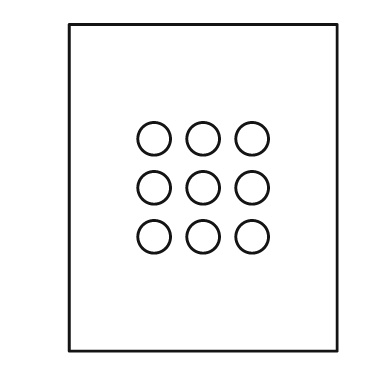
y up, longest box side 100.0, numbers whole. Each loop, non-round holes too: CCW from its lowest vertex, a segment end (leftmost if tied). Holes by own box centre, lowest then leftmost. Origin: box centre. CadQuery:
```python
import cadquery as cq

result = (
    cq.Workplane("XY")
    .moveTo(-41.0, -50.0)
    .lineTo(41.0, -50.0)
    .lineTo(41.0, 50.0)
    .lineTo(-41.0, 50.0)
    .close()
    .moveTo(-15.0, -15.0)
    .circle(5.0)
    .moveTo(0.0, -15.0)
    .circle(5.0)
    .moveTo(15.0, -15.0)
    .circle(5.0)
    .moveTo(-15.0, 0.0)
    .circle(5.0)
    .moveTo(0.0, 0.0)
    .circle(5.0)
    .moveTo(15.0, 0.0)
    .circle(5.0)
    .moveTo(-15.0, 15.0)
    .circle(5.0)
    .moveTo(0.0, 15.0)
    .circle(5.0)
    .moveTo(15.0, 15.0)
    .circle(5.0)
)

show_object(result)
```